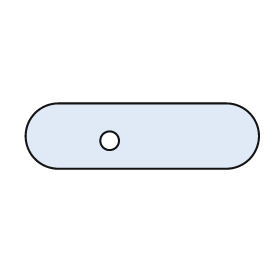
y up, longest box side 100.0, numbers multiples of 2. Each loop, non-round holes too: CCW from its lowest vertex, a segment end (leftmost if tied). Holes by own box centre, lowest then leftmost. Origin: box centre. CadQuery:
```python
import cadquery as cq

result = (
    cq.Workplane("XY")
    .moveTo(-36.0, -14.0)
    .lineTo(36.0, -14.0)
    .threePointArc((50.0, 0.0), (36.0, 14.0))
    .lineTo(-36.0, 14.0)
    .threePointArc((-50.0, 0.0), (-36.0, -14.0))
    .close()
    .moveTo(-14.0, -2.0)
    .circle(4.0)
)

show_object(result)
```